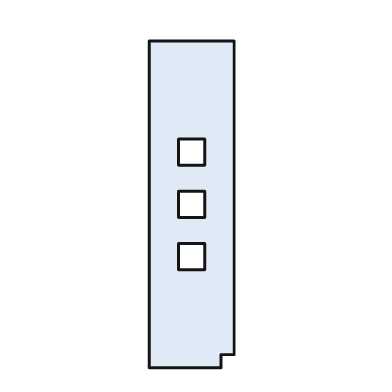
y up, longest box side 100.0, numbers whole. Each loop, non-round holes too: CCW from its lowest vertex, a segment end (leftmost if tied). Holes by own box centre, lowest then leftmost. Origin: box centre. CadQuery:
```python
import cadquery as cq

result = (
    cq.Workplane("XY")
    .moveTo(-13.0, -50.0)
    .lineTo(9.0, -50.0)
    .lineTo(9.0, -46.0)
    .lineTo(13.0, -46.0)
    .lineTo(13.0, 50.0)
    .lineTo(-13.0, 50.0)
    .close()
    .moveTo(-4.0, -20.0)
    .lineTo(4.0, -20.0)
    .lineTo(4.0, -12.0)
    .lineTo(-4.0, -12.0)
    .close()
    .moveTo(-4.0, -4.0)
    .lineTo(4.0, -4.0)
    .lineTo(4.0, 4.0)
    .lineTo(-4.0, 4.0)
    .close()
    .moveTo(-4.0, 12.0)
    .lineTo(4.0, 12.0)
    .lineTo(4.0, 20.0)
    .lineTo(-4.0, 20.0)
    .close()
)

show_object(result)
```